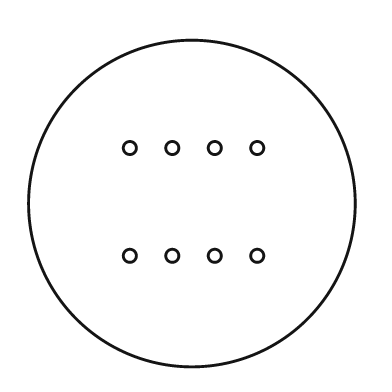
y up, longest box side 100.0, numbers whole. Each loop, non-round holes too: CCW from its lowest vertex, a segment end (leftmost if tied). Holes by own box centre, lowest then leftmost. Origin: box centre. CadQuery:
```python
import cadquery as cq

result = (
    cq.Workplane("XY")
    .moveTo(0.0, 0.0)
    .circle(50.0)
    .moveTo(-19.0, -16.0)
    .circle(2.0)
    .moveTo(-6.0, -16.0)
    .circle(2.0)
    .moveTo(7.0, -16.0)
    .circle(2.0)
    .moveTo(20.0, -16.0)
    .circle(2.0)
    .moveTo(-19.0, 17.0)
    .circle(2.0)
    .moveTo(-6.0, 17.0)
    .circle(2.0)
    .moveTo(7.0, 17.0)
    .circle(2.0)
    .moveTo(20.0, 17.0)
    .circle(2.0)
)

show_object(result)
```